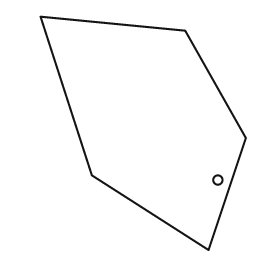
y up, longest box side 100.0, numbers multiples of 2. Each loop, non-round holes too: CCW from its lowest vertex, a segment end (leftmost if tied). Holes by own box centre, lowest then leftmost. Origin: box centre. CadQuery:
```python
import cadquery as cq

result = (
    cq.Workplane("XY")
    .moveTo(28.0, -50.0)
    .lineTo(44.0, -2.0)
    .lineTo(18.0, 44.0)
    .lineTo(-44.0, 50.0)
    .lineTo(-22.0, -18.0)
    .close()
    .moveTo(32.0, -20.0)
    .circle(2.0)
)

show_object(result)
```